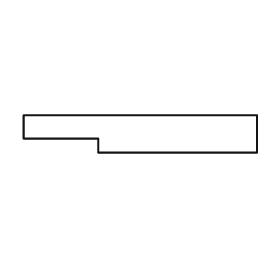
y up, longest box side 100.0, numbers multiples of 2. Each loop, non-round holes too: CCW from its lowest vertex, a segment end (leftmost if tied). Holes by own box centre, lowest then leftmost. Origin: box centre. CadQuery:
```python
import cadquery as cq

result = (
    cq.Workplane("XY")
    .moveTo(-18.0, -8.0)
    .lineTo(50.0, -8.0)
    .lineTo(50.0, 8.0)
    .lineTo(-50.0, 8.0)
    .lineTo(-50.0, -2.0)
    .lineTo(-18.0, -2.0)
    .close()
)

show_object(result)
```